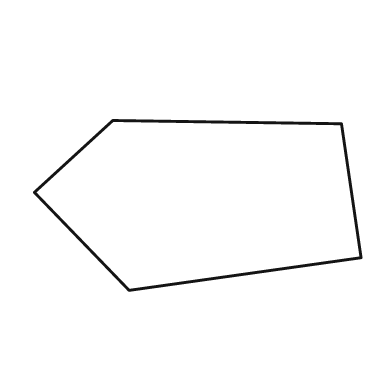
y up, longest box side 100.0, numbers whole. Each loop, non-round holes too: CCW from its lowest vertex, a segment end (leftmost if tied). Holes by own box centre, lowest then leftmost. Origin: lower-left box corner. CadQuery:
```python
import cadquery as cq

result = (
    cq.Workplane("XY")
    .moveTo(29.0, 0.0)
    .lineTo(100.0, 10.0)
    .lineTo(94.0, 51.0)
    .lineTo(24.0, 52.0)
    .lineTo(0.0, 30.0)
    .close()
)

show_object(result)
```